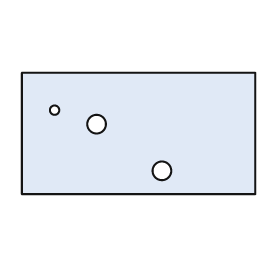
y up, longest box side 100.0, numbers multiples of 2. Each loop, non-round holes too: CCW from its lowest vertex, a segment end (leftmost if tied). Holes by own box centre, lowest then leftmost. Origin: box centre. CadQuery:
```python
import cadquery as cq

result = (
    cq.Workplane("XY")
    .moveTo(-50.0, -26.0)
    .lineTo(50.0, -26.0)
    .lineTo(50.0, 26.0)
    .lineTo(-50.0, 26.0)
    .close()
    .moveTo(10.0, -16.0)
    .circle(4.0)
    .moveTo(-18.0, 4.0)
    .circle(4.0)
    .moveTo(-36.0, 10.0)
    .circle(2.0)
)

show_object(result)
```